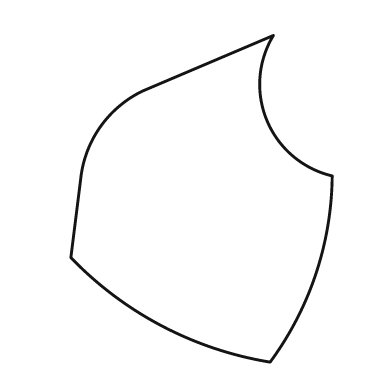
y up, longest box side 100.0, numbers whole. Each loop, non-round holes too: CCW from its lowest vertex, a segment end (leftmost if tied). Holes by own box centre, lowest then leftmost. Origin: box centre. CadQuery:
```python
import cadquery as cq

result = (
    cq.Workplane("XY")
    .moveTo(21.0, -50.0)
    .threePointArc((35.0, -23.0), (40.0, 7.0))
    .threePointArc((20.0, 24.0), (22.0, 50.0))
    .lineTo(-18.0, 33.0)
    .threePointArc((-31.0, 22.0), (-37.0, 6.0))
    .lineTo(-40.0, -18.0)
    .threePointArc((-12.0, -39.0), (21.0, -50.0))
    .close()
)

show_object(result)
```